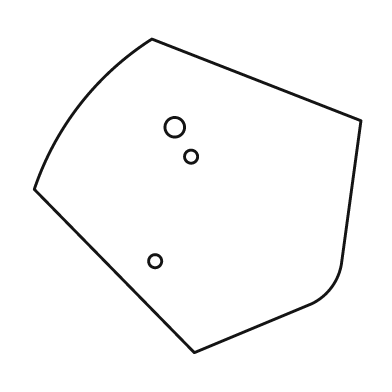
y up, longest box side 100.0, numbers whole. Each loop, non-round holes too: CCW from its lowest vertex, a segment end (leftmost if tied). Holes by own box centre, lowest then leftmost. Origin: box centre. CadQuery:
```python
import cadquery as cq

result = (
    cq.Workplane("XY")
    .moveTo(-1.0, -48.0)
    .lineTo(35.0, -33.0)
    .threePointArc((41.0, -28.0), (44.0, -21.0))
    .lineTo(50.0, 23.0)
    .lineTo(-14.0, 48.0)
    .threePointArc((-36.0, 28.0), (-50.0, 2.0))
    .close()
    .moveTo(-13.0, -20.0)
    .circle(2.0)
    .moveTo(-2.0, 12.0)
    .circle(2.0)
    .moveTo(-7.0, 21.0)
    .circle(3.0)
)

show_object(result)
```